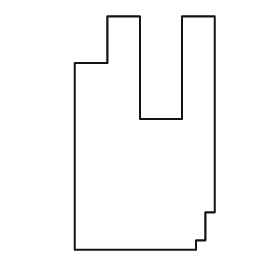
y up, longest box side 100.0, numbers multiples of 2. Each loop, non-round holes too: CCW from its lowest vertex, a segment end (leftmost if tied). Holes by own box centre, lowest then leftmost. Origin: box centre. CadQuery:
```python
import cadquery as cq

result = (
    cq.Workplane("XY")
    .moveTo(-30.0, -50.0)
    .lineTo(22.0, -50.0)
    .lineTo(22.0, -46.0)
    .lineTo(26.0, -46.0)
    .lineTo(26.0, -34.0)
    .lineTo(30.0, -34.0)
    .lineTo(30.0, 50.0)
    .lineTo(16.0, 50.0)
    .lineTo(16.0, 6.0)
    .lineTo(-2.0, 6.0)
    .lineTo(-2.0, 50.0)
    .lineTo(-16.0, 50.0)
    .lineTo(-16.0, 30.0)
    .lineTo(-30.0, 30.0)
    .close()
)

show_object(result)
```